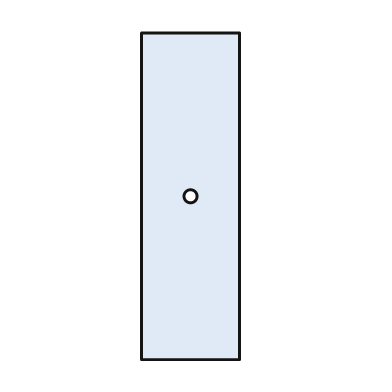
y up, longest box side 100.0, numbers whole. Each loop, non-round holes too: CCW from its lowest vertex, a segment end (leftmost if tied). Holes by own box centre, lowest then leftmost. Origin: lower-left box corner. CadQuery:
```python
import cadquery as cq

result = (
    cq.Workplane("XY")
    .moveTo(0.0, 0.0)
    .lineTo(30.0, 0.0)
    .lineTo(30.0, 100.0)
    .lineTo(0.0, 100.0)
    .close()
    .moveTo(15.0, 50.0)
    .circle(2.0)
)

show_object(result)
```